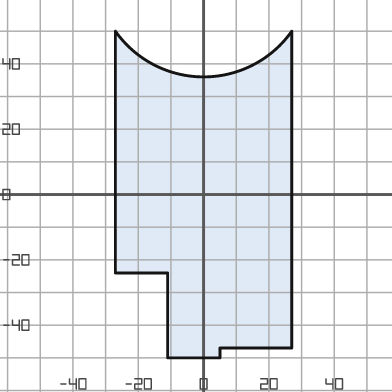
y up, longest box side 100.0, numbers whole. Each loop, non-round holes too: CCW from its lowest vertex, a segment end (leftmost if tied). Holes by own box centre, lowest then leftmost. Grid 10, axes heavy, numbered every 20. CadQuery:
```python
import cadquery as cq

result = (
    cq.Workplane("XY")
    .moveTo(-11.0, -50.0)
    .lineTo(5.0, -50.0)
    .lineTo(5.0, -47.0)
    .lineTo(27.0, -47.0)
    .lineTo(27.0, 50.0)
    .threePointArc((0.0, 36.0), (-27.0, 50.0))
    .lineTo(-27.0, -24.0)
    .lineTo(-11.0, -24.0)
    .close()
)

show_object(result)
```